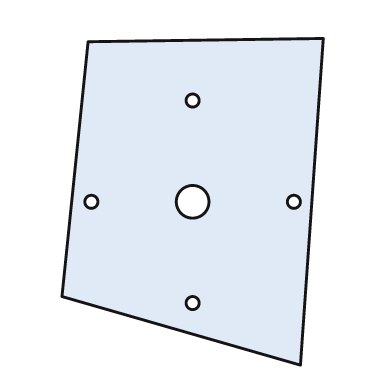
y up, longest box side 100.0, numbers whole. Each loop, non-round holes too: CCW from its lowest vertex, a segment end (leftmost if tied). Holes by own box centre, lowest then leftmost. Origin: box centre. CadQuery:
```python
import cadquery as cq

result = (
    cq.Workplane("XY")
    .moveTo(33.0, -50.0)
    .lineTo(40.0, 50.0)
    .lineTo(-32.0, 49.0)
    .lineTo(-40.0, -29.0)
    .close()
    .moveTo(0.0, -31.0)
    .circle(2.0)
    .moveTo(-31.0, 0.0)
    .circle(2.0)
    .moveTo(0.0, 0.0)
    .circle(5.0)
    .moveTo(31.0, 0.0)
    .circle(2.0)
    .moveTo(0.0, 31.0)
    .circle(2.0)
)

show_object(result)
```